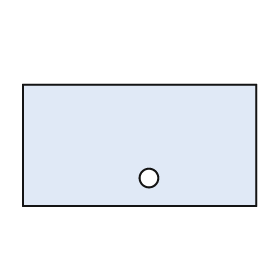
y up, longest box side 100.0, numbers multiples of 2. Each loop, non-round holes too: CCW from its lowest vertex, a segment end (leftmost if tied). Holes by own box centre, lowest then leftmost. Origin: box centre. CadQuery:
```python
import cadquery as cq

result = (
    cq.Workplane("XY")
    .moveTo(-50.0, -26.0)
    .lineTo(50.0, -26.0)
    .lineTo(50.0, 26.0)
    .lineTo(-50.0, 26.0)
    .close()
    .moveTo(4.0, -14.0)
    .circle(4.0)
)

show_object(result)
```